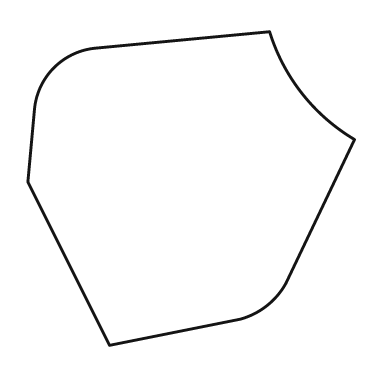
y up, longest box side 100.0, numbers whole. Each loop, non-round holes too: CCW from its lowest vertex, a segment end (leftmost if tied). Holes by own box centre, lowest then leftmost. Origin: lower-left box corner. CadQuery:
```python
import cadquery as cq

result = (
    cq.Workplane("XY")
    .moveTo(25.0, 0.0)
    .lineTo(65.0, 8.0)
    .threePointArc((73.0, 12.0), (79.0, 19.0))
    .lineTo(100.0, 63.0)
    .threePointArc((84.0, 77.0), (74.0, 96.0))
    .lineTo(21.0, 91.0)
    .threePointArc((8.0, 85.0), (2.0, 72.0))
    .lineTo(0.0, 50.0)
    .close()
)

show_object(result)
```